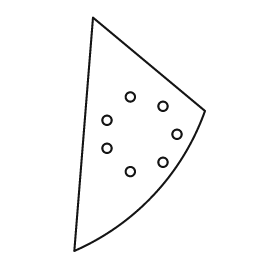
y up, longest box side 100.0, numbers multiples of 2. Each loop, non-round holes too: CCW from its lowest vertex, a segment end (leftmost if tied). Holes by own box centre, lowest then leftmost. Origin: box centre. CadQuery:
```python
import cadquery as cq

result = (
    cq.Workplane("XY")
    .moveTo(-28.0, -50.0)
    .threePointArc((6.0, -26.0), (28.0, 10.0))
    .lineTo(-20.0, 50.0)
    .close()
    .moveTo(-4.0, -16.0)
    .circle(2.0)
    .moveTo(10.0, -12.0)
    .circle(2.0)
    .moveTo(-14.0, -6.0)
    .circle(2.0)
    .moveTo(16.0, 0.0)
    .circle(2.0)
    .moveTo(-14.0, 6.0)
    .circle(2.0)
    .moveTo(10.0, 12.0)
    .circle(2.0)
    .moveTo(-4.0, 16.0)
    .circle(2.0)
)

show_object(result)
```